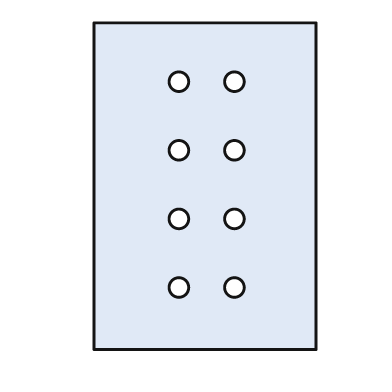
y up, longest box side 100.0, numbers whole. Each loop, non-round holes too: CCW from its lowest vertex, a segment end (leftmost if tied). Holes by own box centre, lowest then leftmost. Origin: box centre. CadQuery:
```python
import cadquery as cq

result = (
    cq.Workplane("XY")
    .moveTo(-34.0, -50.0)
    .lineTo(34.0, -50.0)
    .lineTo(34.0, 50.0)
    .lineTo(-34.0, 50.0)
    .close()
    .moveTo(-8.0, -31.0)
    .circle(3.0)
    .moveTo(9.0, -31.0)
    .circle(3.0)
    .moveTo(-8.0, -10.0)
    .circle(3.0)
    .moveTo(9.0, -10.0)
    .circle(3.0)
    .moveTo(-8.0, 11.0)
    .circle(3.0)
    .moveTo(9.0, 11.0)
    .circle(3.0)
    .moveTo(-8.0, 32.0)
    .circle(3.0)
    .moveTo(9.0, 32.0)
    .circle(3.0)
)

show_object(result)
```